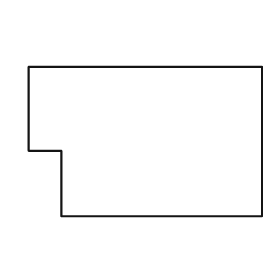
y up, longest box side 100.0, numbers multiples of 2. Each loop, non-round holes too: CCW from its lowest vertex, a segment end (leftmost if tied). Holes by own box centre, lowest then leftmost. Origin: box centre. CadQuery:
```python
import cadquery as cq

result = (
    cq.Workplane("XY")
    .moveTo(-36.0, -32.0)
    .lineTo(50.0, -32.0)
    .lineTo(50.0, 32.0)
    .lineTo(-50.0, 32.0)
    .lineTo(-50.0, -4.0)
    .lineTo(-36.0, -4.0)
    .close()
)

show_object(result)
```